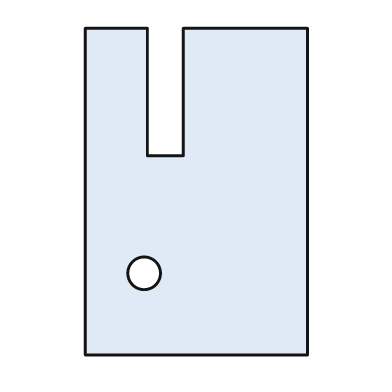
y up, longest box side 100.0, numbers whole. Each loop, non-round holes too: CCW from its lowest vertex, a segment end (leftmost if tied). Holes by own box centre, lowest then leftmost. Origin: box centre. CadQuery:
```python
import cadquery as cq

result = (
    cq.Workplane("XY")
    .moveTo(-34.0, -50.0)
    .lineTo(34.0, -50.0)
    .lineTo(34.0, 50.0)
    .lineTo(-4.0, 50.0)
    .lineTo(-4.0, 11.0)
    .lineTo(-15.0, 11.0)
    .lineTo(-15.0, 50.0)
    .lineTo(-34.0, 50.0)
    .close()
    .moveTo(-16.0, -25.0)
    .circle(5.0)
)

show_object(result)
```